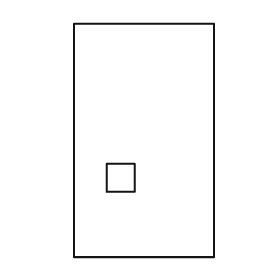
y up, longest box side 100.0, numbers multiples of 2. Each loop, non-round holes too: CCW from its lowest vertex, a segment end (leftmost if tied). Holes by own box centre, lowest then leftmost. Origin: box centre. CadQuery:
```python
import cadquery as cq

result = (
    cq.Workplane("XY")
    .moveTo(-30.0, -50.0)
    .lineTo(30.0, -50.0)
    .lineTo(30.0, 50.0)
    .lineTo(-30.0, 50.0)
    .close()
    .moveTo(-16.0, -22.0)
    .lineTo(-4.0, -22.0)
    .lineTo(-4.0, -10.0)
    .lineTo(-16.0, -10.0)
    .close()
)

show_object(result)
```